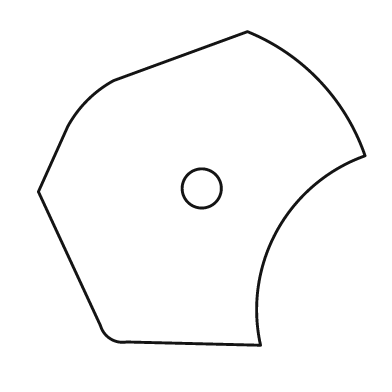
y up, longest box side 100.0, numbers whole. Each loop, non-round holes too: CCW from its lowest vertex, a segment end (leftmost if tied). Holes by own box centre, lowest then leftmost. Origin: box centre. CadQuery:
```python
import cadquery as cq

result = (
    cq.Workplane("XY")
    .moveTo(18.0, -48.0)
    .threePointArc((23.0, -13.0), (50.0, 10.0))
    .threePointArc((36.0, 33.0), (14.0, 48.0))
    .lineTo(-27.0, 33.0)
    .threePointArc((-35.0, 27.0), (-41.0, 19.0))
    .lineTo(-50.0, -1.0)
    .lineTo(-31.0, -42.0)
    .threePointArc((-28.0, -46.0), (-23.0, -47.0))
    .close()
    .moveTo(0.0, 0.0)
    .circle(6.0)
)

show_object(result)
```